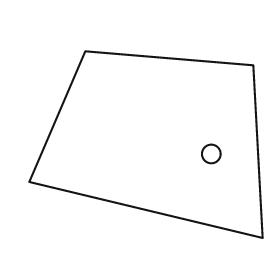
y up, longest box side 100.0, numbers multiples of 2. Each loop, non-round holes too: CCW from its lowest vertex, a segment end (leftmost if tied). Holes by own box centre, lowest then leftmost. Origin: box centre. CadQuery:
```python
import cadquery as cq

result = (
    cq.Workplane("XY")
    .moveTo(50.0, -40.0)
    .lineTo(46.0, 34.0)
    .lineTo(-26.0, 40.0)
    .lineTo(-50.0, -16.0)
    .close()
    .moveTo(28.0, -4.0)
    .circle(4.0)
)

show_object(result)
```